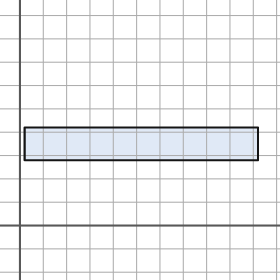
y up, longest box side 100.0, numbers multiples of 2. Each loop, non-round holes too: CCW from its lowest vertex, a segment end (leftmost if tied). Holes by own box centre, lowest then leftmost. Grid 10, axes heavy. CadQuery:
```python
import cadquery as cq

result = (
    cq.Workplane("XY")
    .moveTo(2.0, 28.0)
    .lineTo(102.0, 28.0)
    .lineTo(102.0, 42.0)
    .lineTo(2.0, 42.0)
    .close()
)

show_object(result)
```